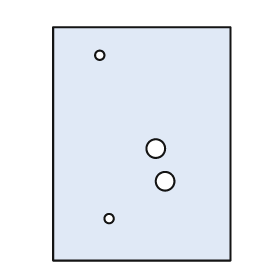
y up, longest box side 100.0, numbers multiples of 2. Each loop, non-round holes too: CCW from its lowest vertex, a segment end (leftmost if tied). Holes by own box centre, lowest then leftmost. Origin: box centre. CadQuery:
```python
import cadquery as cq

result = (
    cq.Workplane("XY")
    .moveTo(-38.0, -50.0)
    .lineTo(38.0, -50.0)
    .lineTo(38.0, 50.0)
    .lineTo(-38.0, 50.0)
    .close()
    .moveTo(-14.0, -32.0)
    .circle(2.0)
    .moveTo(10.0, -16.0)
    .circle(4.0)
    .moveTo(6.0, -2.0)
    .circle(4.0)
    .moveTo(-18.0, 38.0)
    .circle(2.0)
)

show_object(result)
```